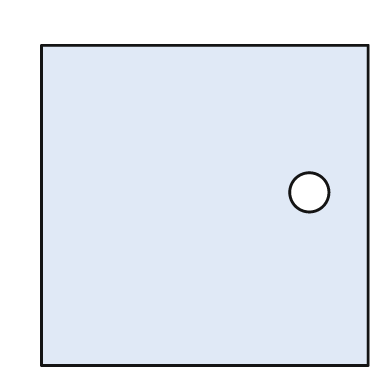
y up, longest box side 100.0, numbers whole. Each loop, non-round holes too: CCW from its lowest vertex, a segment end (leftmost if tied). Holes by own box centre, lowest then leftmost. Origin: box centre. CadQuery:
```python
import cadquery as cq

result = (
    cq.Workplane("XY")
    .moveTo(-50.0, -49.0)
    .lineTo(50.0, -49.0)
    .lineTo(50.0, 49.0)
    .lineTo(-50.0, 49.0)
    .close()
    .moveTo(32.0, 4.0)
    .circle(6.0)
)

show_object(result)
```